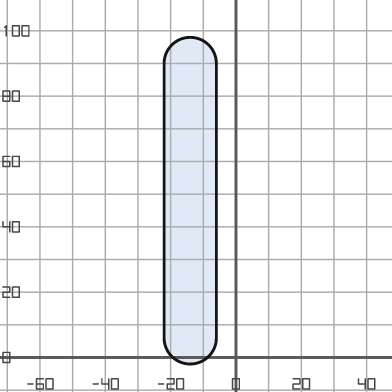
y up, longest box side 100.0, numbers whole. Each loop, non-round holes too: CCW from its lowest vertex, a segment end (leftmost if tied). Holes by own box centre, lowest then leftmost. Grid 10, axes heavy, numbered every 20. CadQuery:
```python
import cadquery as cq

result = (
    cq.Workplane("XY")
    .moveTo(-22.0, 6.0)
    .threePointArc((-14.0, -2.0), (-6.0, 6.0))
    .lineTo(-6.0, 90.0)
    .threePointArc((-14.0, 98.0), (-22.0, 90.0))
    .close()
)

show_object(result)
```